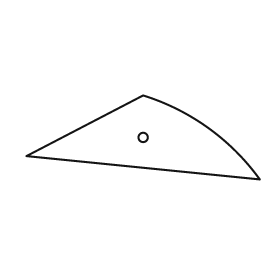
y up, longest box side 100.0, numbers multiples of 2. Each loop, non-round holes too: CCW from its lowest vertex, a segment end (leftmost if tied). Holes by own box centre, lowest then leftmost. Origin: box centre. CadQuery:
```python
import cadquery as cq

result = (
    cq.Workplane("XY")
    .moveTo(50.0, -18.0)
    .threePointArc((28.0, 4.0), (0.0, 18.0))
    .lineTo(-50.0, -8.0)
    .close()
    .moveTo(0.0, 0.0)
    .circle(2.0)
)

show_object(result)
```